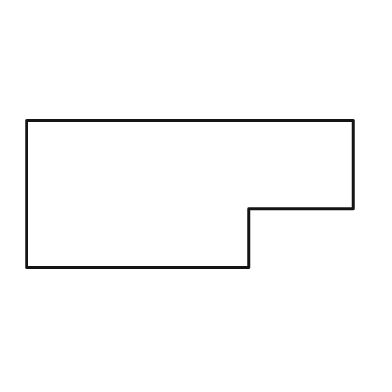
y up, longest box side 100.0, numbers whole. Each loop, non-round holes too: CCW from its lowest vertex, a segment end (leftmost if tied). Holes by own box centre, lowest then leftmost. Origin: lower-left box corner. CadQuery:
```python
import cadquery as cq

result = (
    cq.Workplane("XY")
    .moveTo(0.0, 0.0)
    .lineTo(68.0, 0.0)
    .lineTo(68.0, 18.0)
    .lineTo(100.0, 18.0)
    .lineTo(100.0, 45.0)
    .lineTo(0.0, 45.0)
    .close()
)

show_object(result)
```